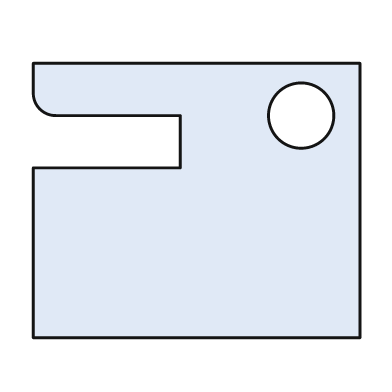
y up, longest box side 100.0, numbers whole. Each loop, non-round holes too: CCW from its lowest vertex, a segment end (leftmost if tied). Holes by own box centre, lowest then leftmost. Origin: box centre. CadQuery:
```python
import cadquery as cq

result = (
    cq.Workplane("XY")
    .moveTo(-50.0, -42.0)
    .lineTo(50.0, -42.0)
    .lineTo(50.0, 42.0)
    .lineTo(-50.0, 42.0)
    .lineTo(-50.0, 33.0)
    .threePointArc((-48.0, 28.0), (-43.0, 26.0))
    .lineTo(-5.0, 26.0)
    .lineTo(-5.0, 10.0)
    .lineTo(-50.0, 10.0)
    .close()
    .moveTo(32.0, 26.0)
    .circle(10.0)
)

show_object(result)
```